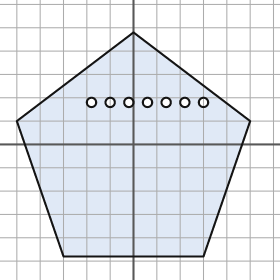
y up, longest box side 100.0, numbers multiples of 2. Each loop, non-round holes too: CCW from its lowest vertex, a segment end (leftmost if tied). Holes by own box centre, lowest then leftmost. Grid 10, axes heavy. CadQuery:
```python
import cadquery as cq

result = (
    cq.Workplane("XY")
    .moveTo(-30.0, -48.0)
    .lineTo(30.0, -48.0)
    .lineTo(50.0, 10.0)
    .lineTo(0.0, 48.0)
    .lineTo(-50.0, 10.0)
    .close()
    .moveTo(-18.0, 18.0)
    .circle(2.0)
    .moveTo(-10.0, 18.0)
    .circle(2.0)
    .moveTo(-2.0, 18.0)
    .circle(2.0)
    .moveTo(6.0, 18.0)
    .circle(2.0)
    .moveTo(14.0, 18.0)
    .circle(2.0)
    .moveTo(22.0, 18.0)
    .circle(2.0)
    .moveTo(30.0, 18.0)
    .circle(2.0)
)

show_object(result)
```